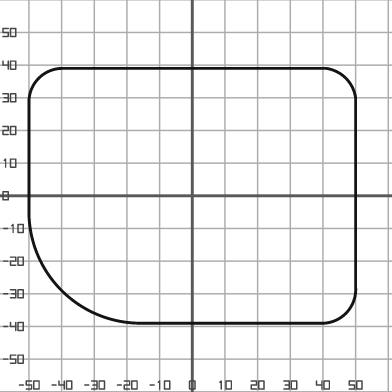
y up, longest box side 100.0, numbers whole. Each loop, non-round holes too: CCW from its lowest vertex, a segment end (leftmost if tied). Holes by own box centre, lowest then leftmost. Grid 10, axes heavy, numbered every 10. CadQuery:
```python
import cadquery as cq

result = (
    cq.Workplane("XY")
    .moveTo(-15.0, -39.0)
    .lineTo(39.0, -39.0)
    .threePointArc((47.0, -36.0), (50.0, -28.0))
    .lineTo(50.0, 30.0)
    .threePointArc((47.0, 36.0), (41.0, 39.0))
    .lineTo(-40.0, 39.0)
    .threePointArc((-47.0, 36.0), (-50.0, 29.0))
    .lineTo(-50.0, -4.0)
    .threePointArc((-40.0, -29.0), (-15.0, -39.0))
    .close()
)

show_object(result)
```